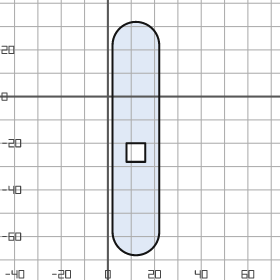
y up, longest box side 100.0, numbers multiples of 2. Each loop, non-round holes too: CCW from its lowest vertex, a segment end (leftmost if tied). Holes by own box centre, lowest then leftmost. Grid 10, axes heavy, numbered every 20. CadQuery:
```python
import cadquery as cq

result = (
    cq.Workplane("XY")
    .moveTo(2.0, -58.0)
    .threePointArc((12.0, -68.0), (22.0, -58.0))
    .lineTo(22.0, 22.0)
    .threePointArc((12.0, 32.0), (2.0, 22.0))
    .close()
    .moveTo(8.0, -28.0)
    .lineTo(16.0, -28.0)
    .lineTo(16.0, -20.0)
    .lineTo(8.0, -20.0)
    .close()
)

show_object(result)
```